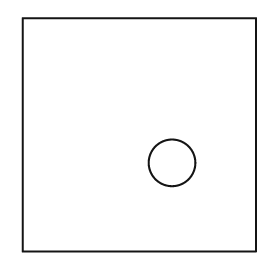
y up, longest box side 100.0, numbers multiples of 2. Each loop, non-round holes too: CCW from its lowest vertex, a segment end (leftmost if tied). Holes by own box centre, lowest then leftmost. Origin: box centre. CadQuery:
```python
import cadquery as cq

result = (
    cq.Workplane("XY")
    .moveTo(-50.0, -50.0)
    .lineTo(50.0, -50.0)
    .lineTo(50.0, 50.0)
    .lineTo(-50.0, 50.0)
    .close()
    .moveTo(14.0, -12.0)
    .circle(10.0)
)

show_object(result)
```